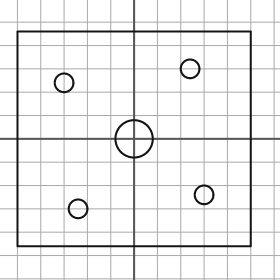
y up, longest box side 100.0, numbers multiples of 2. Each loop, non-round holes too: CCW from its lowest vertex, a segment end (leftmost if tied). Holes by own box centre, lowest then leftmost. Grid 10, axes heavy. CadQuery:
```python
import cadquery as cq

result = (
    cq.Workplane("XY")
    .moveTo(-50.0, -46.0)
    .lineTo(50.0, -46.0)
    .lineTo(50.0, 46.0)
    .lineTo(-50.0, 46.0)
    .close()
    .moveTo(-24.0, -30.0)
    .circle(4.0)
    .moveTo(30.0, -24.0)
    .circle(4.0)
    .moveTo(0.0, 0.0)
    .circle(8.0)
    .moveTo(-30.0, 24.0)
    .circle(4.0)
    .moveTo(24.0, 30.0)
    .circle(4.0)
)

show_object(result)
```